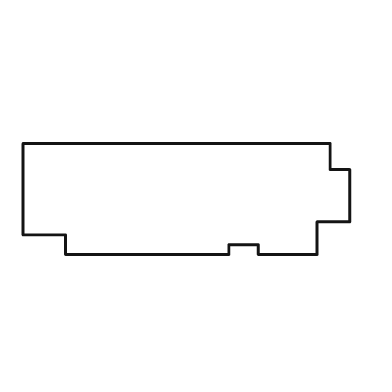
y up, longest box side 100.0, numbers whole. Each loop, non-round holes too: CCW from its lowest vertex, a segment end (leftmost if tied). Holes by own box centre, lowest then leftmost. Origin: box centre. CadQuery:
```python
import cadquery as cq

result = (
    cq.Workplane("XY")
    .moveTo(-37.0, -17.0)
    .lineTo(13.0, -17.0)
    .lineTo(13.0, -14.0)
    .lineTo(22.0, -14.0)
    .lineTo(22.0, -17.0)
    .lineTo(40.0, -17.0)
    .lineTo(40.0, -7.0)
    .lineTo(50.0, -7.0)
    .lineTo(50.0, 9.0)
    .lineTo(44.0, 9.0)
    .lineTo(44.0, 17.0)
    .lineTo(-50.0, 17.0)
    .lineTo(-50.0, -11.0)
    .lineTo(-37.0, -11.0)
    .close()
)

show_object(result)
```